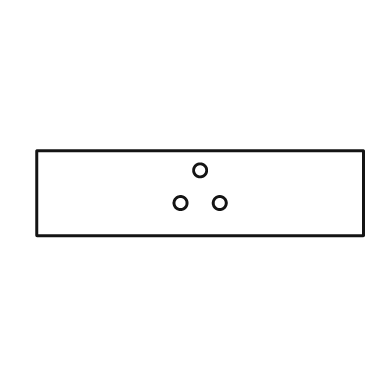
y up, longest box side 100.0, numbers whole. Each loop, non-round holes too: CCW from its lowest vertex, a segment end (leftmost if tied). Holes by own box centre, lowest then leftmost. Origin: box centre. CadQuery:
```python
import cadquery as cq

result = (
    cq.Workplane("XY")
    .moveTo(-50.0, -13.0)
    .lineTo(50.0, -13.0)
    .lineTo(50.0, 13.0)
    .lineTo(-50.0, 13.0)
    .close()
    .moveTo(-6.0, -3.0)
    .circle(2.0)
    .moveTo(6.0, -3.0)
    .circle(2.0)
    .moveTo(0.0, 7.0)
    .circle(2.0)
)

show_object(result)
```